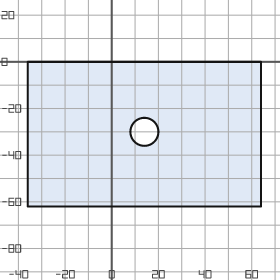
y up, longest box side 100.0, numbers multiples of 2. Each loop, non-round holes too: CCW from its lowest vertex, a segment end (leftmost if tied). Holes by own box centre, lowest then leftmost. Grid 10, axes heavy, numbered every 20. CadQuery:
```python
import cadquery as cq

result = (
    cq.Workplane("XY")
    .moveTo(-36.0, -62.0)
    .lineTo(64.0, -62.0)
    .lineTo(64.0, 0.0)
    .lineTo(-36.0, 0.0)
    .close()
    .moveTo(14.0, -30.0)
    .circle(6.0)
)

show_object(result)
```